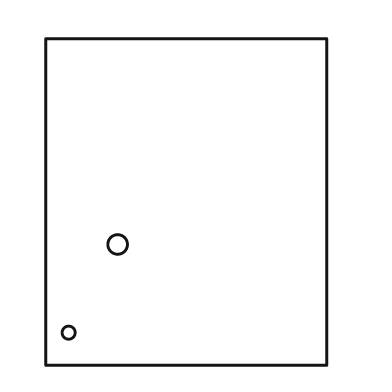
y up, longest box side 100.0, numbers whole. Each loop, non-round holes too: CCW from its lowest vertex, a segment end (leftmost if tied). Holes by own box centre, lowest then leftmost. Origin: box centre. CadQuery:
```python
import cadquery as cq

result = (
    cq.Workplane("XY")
    .moveTo(-43.0, -50.0)
    .lineTo(43.0, -50.0)
    .lineTo(43.0, 50.0)
    .lineTo(-43.0, 50.0)
    .close()
    .moveTo(-36.0, -40.0)
    .circle(2.0)
    .moveTo(-21.0, -13.0)
    .circle(3.0)
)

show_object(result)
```